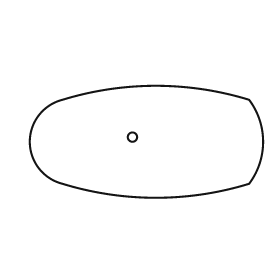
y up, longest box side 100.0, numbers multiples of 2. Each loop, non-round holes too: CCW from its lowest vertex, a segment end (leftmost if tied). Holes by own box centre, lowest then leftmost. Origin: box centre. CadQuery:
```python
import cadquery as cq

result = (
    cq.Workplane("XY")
    .moveTo(-36.0, -18.0)
    .threePointArc((4.0, -24.0), (44.0, -18.0))
    .threePointArc((50.0, 0.0), (44.0, 18.0))
    .threePointArc((4.0, 24.0), (-36.0, 18.0))
    .threePointArc((-50.0, 0.0), (-36.0, -18.0))
    .close()
    .moveTo(-6.0, 2.0)
    .circle(2.0)
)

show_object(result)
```